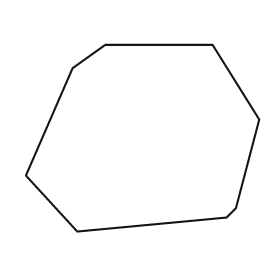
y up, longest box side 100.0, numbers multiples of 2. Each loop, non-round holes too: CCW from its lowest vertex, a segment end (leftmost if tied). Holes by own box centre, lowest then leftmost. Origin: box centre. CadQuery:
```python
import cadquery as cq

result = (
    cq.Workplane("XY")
    .moveTo(-28.0, -40.0)
    .lineTo(36.0, -34.0)
    .lineTo(40.0, -30.0)
    .lineTo(50.0, 8.0)
    .lineTo(30.0, 40.0)
    .lineTo(-16.0, 40.0)
    .lineTo(-30.0, 30.0)
    .lineTo(-50.0, -16.0)
    .close()
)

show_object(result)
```